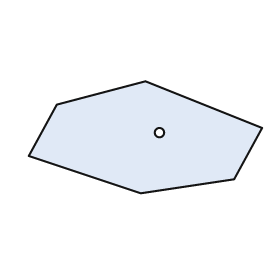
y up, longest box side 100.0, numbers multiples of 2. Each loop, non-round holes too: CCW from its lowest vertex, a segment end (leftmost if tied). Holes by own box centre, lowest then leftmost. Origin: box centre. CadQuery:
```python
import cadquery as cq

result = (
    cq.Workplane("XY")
    .moveTo(-2.0, -24.0)
    .lineTo(38.0, -18.0)
    .lineTo(50.0, 4.0)
    .lineTo(0.0, 24.0)
    .lineTo(-38.0, 14.0)
    .lineTo(-50.0, -8.0)
    .close()
    .moveTo(6.0, 2.0)
    .circle(2.0)
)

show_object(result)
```